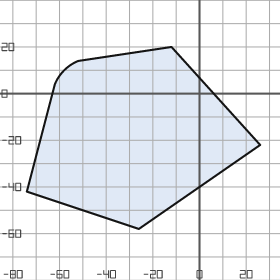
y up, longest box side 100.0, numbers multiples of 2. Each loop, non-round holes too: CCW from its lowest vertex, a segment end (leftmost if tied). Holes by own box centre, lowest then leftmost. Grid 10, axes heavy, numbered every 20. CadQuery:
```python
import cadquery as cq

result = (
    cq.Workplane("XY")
    .moveTo(-26.0, -58.0)
    .lineTo(26.0, -22.0)
    .lineTo(-12.0, 20.0)
    .lineTo(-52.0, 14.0)
    .threePointArc((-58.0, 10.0), (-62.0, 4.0))
    .lineTo(-74.0, -42.0)
    .close()
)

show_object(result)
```